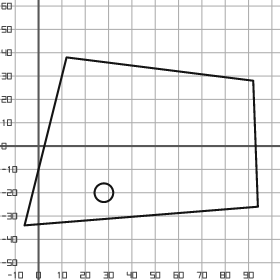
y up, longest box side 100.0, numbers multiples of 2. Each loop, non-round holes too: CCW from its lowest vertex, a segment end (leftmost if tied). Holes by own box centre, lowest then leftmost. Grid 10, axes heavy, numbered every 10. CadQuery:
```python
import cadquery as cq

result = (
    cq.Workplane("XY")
    .moveTo(-6.0, -34.0)
    .lineTo(94.0, -26.0)
    .lineTo(92.0, 28.0)
    .lineTo(12.0, 38.0)
    .close()
    .moveTo(28.0, -20.0)
    .circle(4.0)
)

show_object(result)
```